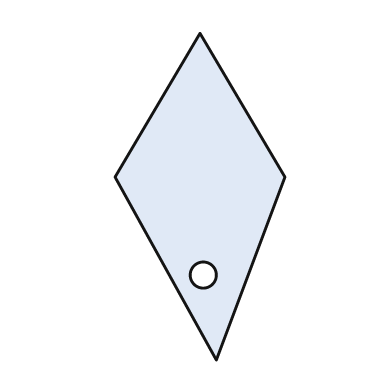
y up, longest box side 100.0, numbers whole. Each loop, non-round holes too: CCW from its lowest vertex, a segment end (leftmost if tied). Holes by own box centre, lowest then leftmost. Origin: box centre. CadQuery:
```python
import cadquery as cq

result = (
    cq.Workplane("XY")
    .moveTo(5.0, -50.0)
    .lineTo(26.0, 6.0)
    .lineTo(0.0, 50.0)
    .lineTo(-26.0, 6.0)
    .close()
    .moveTo(1.0, -24.0)
    .circle(4.0)
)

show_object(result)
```